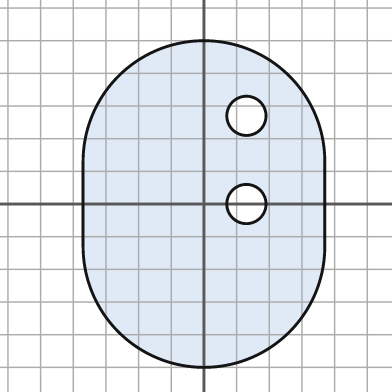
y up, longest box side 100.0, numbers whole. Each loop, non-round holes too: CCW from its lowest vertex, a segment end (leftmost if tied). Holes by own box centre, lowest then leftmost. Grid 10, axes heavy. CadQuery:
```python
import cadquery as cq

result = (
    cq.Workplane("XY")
    .moveTo(-37.0, -13.0)
    .threePointArc((0.0, -50.0), (37.0, -13.0))
    .lineTo(37.0, 13.0)
    .threePointArc((0.0, 50.0), (-37.0, 13.0))
    .close()
    .moveTo(13.0, 0.0)
    .circle(6.0)
    .moveTo(13.0, 27.0)
    .circle(6.0)
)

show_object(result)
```